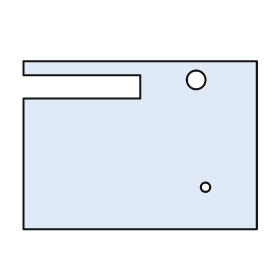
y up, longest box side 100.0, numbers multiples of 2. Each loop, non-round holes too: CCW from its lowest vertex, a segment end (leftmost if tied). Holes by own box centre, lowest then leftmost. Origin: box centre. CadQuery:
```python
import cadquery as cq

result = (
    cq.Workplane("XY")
    .moveTo(-50.0, -36.0)
    .lineTo(50.0, -36.0)
    .lineTo(50.0, 36.0)
    .lineTo(-50.0, 36.0)
    .lineTo(-50.0, 30.0)
    .lineTo(0.0, 30.0)
    .lineTo(0.0, 20.0)
    .lineTo(-50.0, 20.0)
    .close()
    .moveTo(28.0, -18.0)
    .circle(2.0)
    .moveTo(24.0, 28.0)
    .circle(4.0)
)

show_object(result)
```